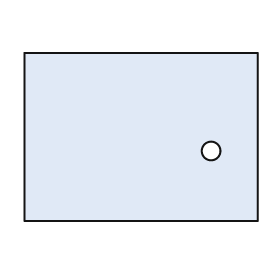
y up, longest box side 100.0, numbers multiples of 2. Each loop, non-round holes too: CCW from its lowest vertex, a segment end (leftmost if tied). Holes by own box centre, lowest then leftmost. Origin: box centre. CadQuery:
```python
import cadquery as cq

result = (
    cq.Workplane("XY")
    .moveTo(-50.0, -36.0)
    .lineTo(50.0, -36.0)
    .lineTo(50.0, 36.0)
    .lineTo(-50.0, 36.0)
    .close()
    .moveTo(30.0, -6.0)
    .circle(4.0)
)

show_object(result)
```